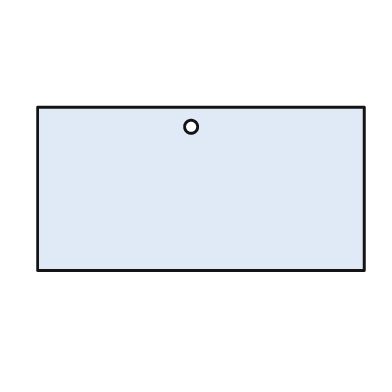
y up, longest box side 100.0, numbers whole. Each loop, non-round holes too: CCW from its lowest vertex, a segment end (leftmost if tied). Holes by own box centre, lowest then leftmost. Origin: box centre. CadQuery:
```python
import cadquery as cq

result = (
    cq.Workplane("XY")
    .moveTo(-50.0, -25.0)
    .lineTo(50.0, -25.0)
    .lineTo(50.0, 25.0)
    .lineTo(-50.0, 25.0)
    .close()
    .moveTo(-3.0, 19.0)
    .circle(2.0)
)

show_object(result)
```